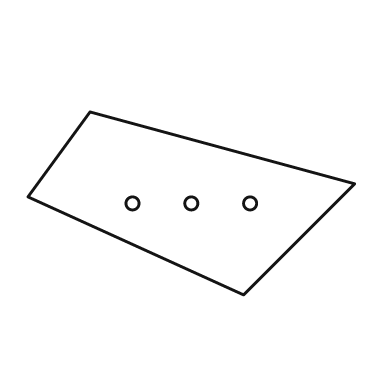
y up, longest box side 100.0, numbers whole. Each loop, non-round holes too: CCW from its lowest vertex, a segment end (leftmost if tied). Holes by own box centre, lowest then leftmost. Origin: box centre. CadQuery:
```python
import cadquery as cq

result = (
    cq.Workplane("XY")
    .moveTo(16.0, -28.0)
    .lineTo(50.0, 6.0)
    .lineTo(-31.0, 28.0)
    .lineTo(-50.0, 2.0)
    .close()
    .moveTo(-18.0, 0.0)
    .circle(2.0)
    .moveTo(0.0, 0.0)
    .circle(2.0)
    .moveTo(18.0, 0.0)
    .circle(2.0)
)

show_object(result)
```